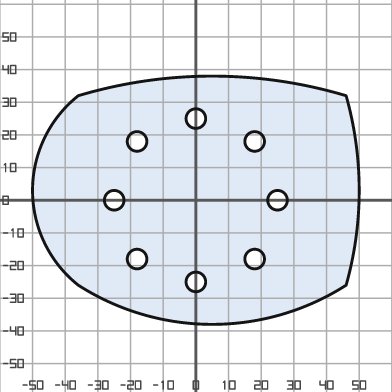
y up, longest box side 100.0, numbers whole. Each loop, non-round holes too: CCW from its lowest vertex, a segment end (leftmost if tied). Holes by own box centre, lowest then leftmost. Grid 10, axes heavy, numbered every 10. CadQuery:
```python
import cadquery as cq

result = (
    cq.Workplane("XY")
    .moveTo(-36.0, -26.0)
    .threePointArc((5.0, -38.0), (46.0, -26.0))
    .threePointArc((50.0, 3.0), (46.0, 32.0))
    .threePointArc((5.0, 38.0), (-36.0, 32.0))
    .threePointArc((-50.0, 3.0), (-36.0, -26.0))
    .close()
    .moveTo(0.0, -25.0)
    .circle(3.0)
    .moveTo(-18.0, -18.0)
    .circle(3.0)
    .moveTo(18.0, -18.0)
    .circle(3.0)
    .moveTo(-25.0, 0.0)
    .circle(3.0)
    .moveTo(25.0, 0.0)
    .circle(3.0)
    .moveTo(-18.0, 18.0)
    .circle(3.0)
    .moveTo(18.0, 18.0)
    .circle(3.0)
    .moveTo(0.0, 25.0)
    .circle(3.0)
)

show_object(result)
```